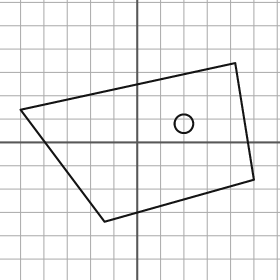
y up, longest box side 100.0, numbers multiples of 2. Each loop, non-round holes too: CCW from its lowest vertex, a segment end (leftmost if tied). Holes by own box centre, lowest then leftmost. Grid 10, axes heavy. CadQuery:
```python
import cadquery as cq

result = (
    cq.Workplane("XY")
    .moveTo(-14.0, -34.0)
    .lineTo(50.0, -16.0)
    .lineTo(42.0, 34.0)
    .lineTo(-50.0, 14.0)
    .close()
    .moveTo(20.0, 8.0)
    .circle(4.0)
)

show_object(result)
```